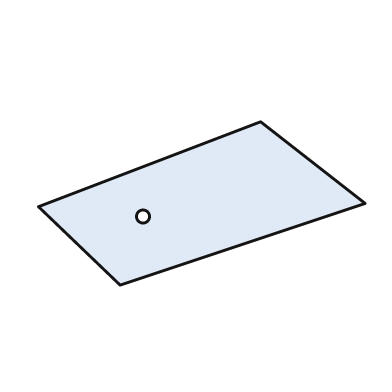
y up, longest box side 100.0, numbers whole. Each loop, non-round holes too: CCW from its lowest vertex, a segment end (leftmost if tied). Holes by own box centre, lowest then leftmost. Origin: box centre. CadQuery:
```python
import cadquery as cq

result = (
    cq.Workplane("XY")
    .moveTo(-25.0, -25.0)
    .lineTo(50.0, 0.0)
    .lineTo(18.0, 25.0)
    .lineTo(-50.0, -1.0)
    .close()
    .moveTo(-18.0, -4.0)
    .circle(2.0)
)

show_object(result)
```